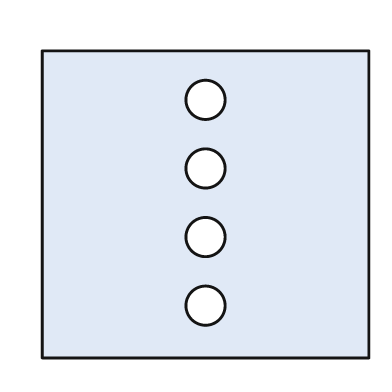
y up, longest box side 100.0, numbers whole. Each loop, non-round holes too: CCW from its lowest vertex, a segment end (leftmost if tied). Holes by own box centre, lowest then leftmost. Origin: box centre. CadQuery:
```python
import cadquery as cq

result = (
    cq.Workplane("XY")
    .moveTo(-50.0, -47.0)
    .lineTo(50.0, -47.0)
    .lineTo(50.0, 47.0)
    .lineTo(-50.0, 47.0)
    .close()
    .moveTo(0.0, -31.0)
    .circle(6.0)
    .moveTo(0.0, -10.0)
    .circle(6.0)
    .moveTo(0.0, 11.0)
    .circle(6.0)
    .moveTo(0.0, 32.0)
    .circle(6.0)
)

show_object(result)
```